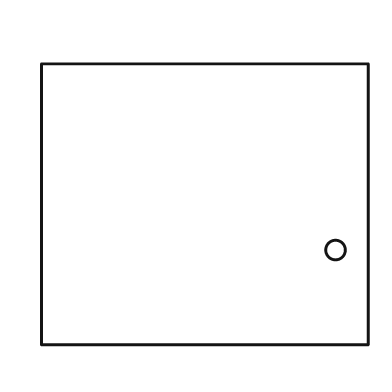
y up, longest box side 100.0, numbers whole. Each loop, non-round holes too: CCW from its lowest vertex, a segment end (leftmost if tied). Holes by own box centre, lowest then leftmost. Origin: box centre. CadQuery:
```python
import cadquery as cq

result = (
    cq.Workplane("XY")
    .moveTo(-50.0, -43.0)
    .lineTo(50.0, -43.0)
    .lineTo(50.0, 43.0)
    .lineTo(-50.0, 43.0)
    .close()
    .moveTo(40.0, -14.0)
    .circle(3.0)
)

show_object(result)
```